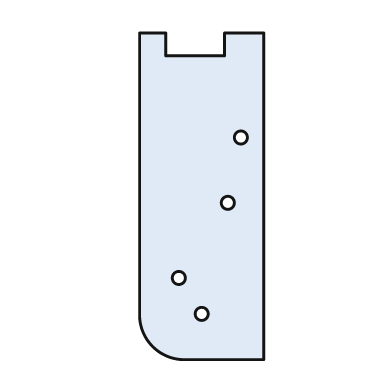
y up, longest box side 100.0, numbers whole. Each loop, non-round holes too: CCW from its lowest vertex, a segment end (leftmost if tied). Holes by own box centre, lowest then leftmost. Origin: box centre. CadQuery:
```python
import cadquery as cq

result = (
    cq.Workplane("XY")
    .moveTo(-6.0, -50.0)
    .lineTo(19.0, -50.0)
    .lineTo(19.0, 50.0)
    .lineTo(7.0, 50.0)
    .lineTo(7.0, 43.0)
    .lineTo(-11.0, 43.0)
    .lineTo(-11.0, 50.0)
    .lineTo(-19.0, 50.0)
    .lineTo(-19.0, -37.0)
    .threePointArc((-15.0, -46.0), (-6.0, -50.0))
    .close()
    .moveTo(0.0, -36.0)
    .circle(2.0)
    .moveTo(-7.0, -25.0)
    .circle(2.0)
    .moveTo(8.0, -2.0)
    .circle(2.0)
    .moveTo(12.0, 18.0)
    .circle(2.0)
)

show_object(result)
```